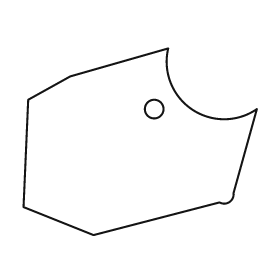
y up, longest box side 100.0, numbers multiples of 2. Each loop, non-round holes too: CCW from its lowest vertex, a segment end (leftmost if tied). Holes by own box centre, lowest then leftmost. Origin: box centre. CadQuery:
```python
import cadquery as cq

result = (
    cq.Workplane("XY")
    .moveTo(-20.0, -40.0)
    .lineTo(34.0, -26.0)
    .threePointArc((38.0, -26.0), (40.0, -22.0))
    .lineTo(50.0, 14.0)
    .threePointArc((22.0, 14.0), (12.0, 40.0))
    .lineTo(-30.0, 28.0)
    .lineTo(-48.0, 18.0)
    .lineTo(-50.0, -28.0)
    .close()
    .moveTo(6.0, 14.0)
    .circle(4.0)
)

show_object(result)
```